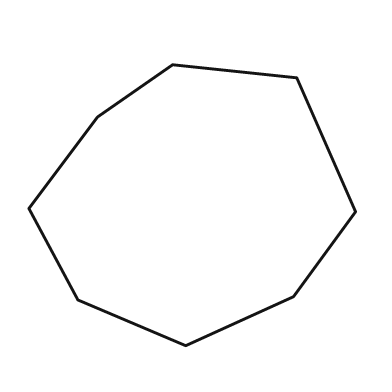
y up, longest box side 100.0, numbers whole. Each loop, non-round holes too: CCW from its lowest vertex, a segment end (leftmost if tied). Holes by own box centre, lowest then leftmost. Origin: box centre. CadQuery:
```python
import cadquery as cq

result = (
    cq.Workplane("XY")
    .moveTo(-2.0, -43.0)
    .lineTo(31.0, -28.0)
    .lineTo(50.0, -2.0)
    .lineTo(32.0, 39.0)
    .lineTo(-6.0, 43.0)
    .lineTo(-29.0, 27.0)
    .lineTo(-50.0, -1.0)
    .lineTo(-35.0, -29.0)
    .close()
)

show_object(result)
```